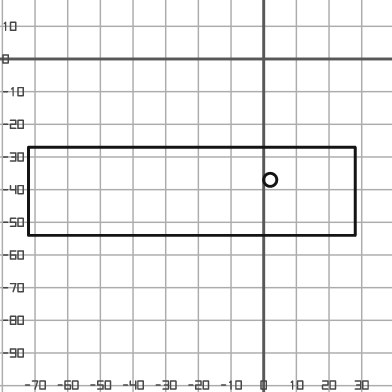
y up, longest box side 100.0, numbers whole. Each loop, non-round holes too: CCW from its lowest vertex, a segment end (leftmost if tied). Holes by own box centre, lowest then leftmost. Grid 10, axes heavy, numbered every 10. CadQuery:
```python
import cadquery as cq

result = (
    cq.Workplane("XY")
    .moveTo(-72.0, -54.0)
    .lineTo(28.0, -54.0)
    .lineTo(28.0, -27.0)
    .lineTo(-72.0, -27.0)
    .close()
    .moveTo(2.0, -37.0)
    .circle(2.0)
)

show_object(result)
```